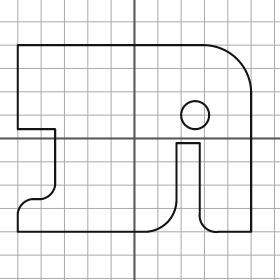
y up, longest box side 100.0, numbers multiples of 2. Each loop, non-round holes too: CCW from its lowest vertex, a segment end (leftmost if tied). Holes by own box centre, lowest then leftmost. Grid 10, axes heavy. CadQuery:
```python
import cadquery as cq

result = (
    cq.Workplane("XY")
    .moveTo(-50.0, -40.0)
    .lineTo(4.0, -40.0)
    .threePointArc((14.0, -36.0), (18.0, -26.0))
    .lineTo(18.0, -2.0)
    .lineTo(28.0, -2.0)
    .lineTo(28.0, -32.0)
    .threePointArc((30.0, -38.0), (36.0, -40.0))
    .lineTo(50.0, -40.0)
    .lineTo(50.0, 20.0)
    .threePointArc((44.0, 34.0), (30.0, 40.0))
    .lineTo(-50.0, 40.0)
    .lineTo(-50.0, 4.0)
    .lineTo(-34.0, 4.0)
    .lineTo(-34.0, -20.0)
    .threePointArc((-36.0, -24.0), (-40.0, -26.0))
    .lineTo(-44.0, -26.0)
    .threePointArc((-48.0, -28.0), (-50.0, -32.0))
    .close()
    .moveTo(26.0, 10.0)
    .circle(6.0)
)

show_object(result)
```